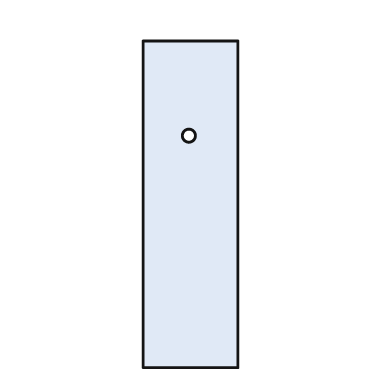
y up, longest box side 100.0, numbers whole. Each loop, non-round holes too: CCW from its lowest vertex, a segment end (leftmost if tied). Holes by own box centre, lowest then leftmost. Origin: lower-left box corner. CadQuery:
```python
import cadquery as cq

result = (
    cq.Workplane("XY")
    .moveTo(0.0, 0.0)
    .lineTo(29.0, 0.0)
    .lineTo(29.0, 100.0)
    .lineTo(0.0, 100.0)
    .close()
    .moveTo(14.0, 71.0)
    .circle(2.0)
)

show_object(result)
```